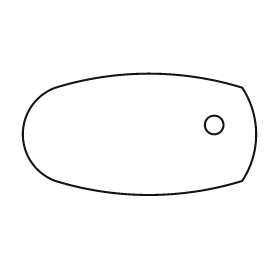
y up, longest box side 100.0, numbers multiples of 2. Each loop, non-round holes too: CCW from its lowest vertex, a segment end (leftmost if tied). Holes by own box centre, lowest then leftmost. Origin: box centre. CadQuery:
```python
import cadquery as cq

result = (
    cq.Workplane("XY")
    .moveTo(-36.0, -20.0)
    .threePointArc((4.0, -26.0), (44.0, -20.0))
    .threePointArc((50.0, 0.0), (44.0, 20.0))
    .threePointArc((4.0, 26.0), (-36.0, 20.0))
    .threePointArc((-50.0, 0.0), (-36.0, -20.0))
    .close()
    .moveTo(32.0, 4.0)
    .circle(4.0)
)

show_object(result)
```